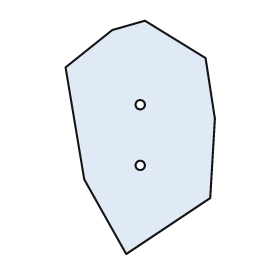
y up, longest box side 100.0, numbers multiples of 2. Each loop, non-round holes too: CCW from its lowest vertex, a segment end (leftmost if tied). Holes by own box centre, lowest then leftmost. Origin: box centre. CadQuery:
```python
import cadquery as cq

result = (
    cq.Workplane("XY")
    .moveTo(-6.0, -50.0)
    .lineTo(30.0, -26.0)
    .lineTo(32.0, 8.0)
    .lineTo(28.0, 34.0)
    .lineTo(2.0, 50.0)
    .lineTo(-12.0, 46.0)
    .lineTo(-32.0, 30.0)
    .lineTo(-24.0, -18.0)
    .close()
    .moveTo(0.0, -12.0)
    .circle(2.0)
    .moveTo(0.0, 14.0)
    .circle(2.0)
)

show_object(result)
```